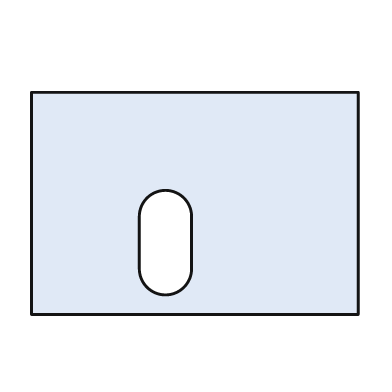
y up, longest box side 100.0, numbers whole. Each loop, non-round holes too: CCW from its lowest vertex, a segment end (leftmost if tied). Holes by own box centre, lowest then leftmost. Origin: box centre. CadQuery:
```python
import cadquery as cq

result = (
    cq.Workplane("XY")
    .moveTo(-50.0, -34.0)
    .lineTo(50.0, -34.0)
    .lineTo(50.0, 34.0)
    .lineTo(-50.0, 34.0)
    .close()
    .moveTo(-17.0, -20.0)
    .threePointArc((-9.0, -28.0), (-1.0, -20.0))
    .lineTo(-1.0, -4.0)
    .threePointArc((-9.0, 4.0), (-17.0, -4.0))
    .close()
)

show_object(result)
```